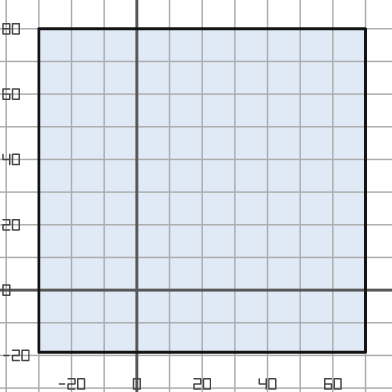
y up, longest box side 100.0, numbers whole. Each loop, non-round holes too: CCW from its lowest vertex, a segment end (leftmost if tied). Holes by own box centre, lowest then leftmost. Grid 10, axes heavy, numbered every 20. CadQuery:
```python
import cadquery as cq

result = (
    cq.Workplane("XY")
    .moveTo(-30.0, -19.0)
    .lineTo(70.0, -19.0)
    .lineTo(70.0, 80.0)
    .lineTo(-30.0, 80.0)
    .close()
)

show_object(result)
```